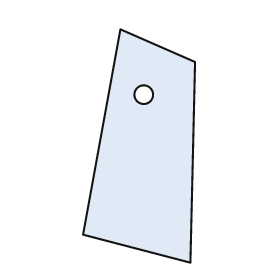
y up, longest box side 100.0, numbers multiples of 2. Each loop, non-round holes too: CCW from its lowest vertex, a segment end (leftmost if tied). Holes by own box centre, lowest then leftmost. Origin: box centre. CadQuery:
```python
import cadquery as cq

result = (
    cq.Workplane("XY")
    .moveTo(22.0, -50.0)
    .lineTo(24.0, 36.0)
    .lineTo(-8.0, 50.0)
    .lineTo(-24.0, -38.0)
    .close()
    .moveTo(2.0, 22.0)
    .circle(4.0)
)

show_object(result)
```